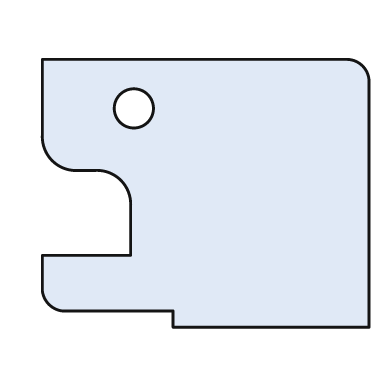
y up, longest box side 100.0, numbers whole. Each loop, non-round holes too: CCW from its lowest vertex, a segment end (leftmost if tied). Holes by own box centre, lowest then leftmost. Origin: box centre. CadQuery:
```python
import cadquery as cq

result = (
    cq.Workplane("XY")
    .moveTo(-10.0, -41.0)
    .lineTo(50.0, -41.0)
    .lineTo(50.0, 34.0)
    .threePointArc((48.0, 39.0), (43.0, 41.0))
    .lineTo(-50.0, 41.0)
    .lineTo(-50.0, 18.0)
    .threePointArc((-47.0, 10.0), (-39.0, 7.0))
    .lineTo(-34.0, 7.0)
    .threePointArc((-26.0, 4.0), (-23.0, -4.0))
    .lineTo(-23.0, -19.0)
    .lineTo(-50.0, -19.0)
    .lineTo(-50.0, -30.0)
    .threePointArc((-48.0, -34.0), (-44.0, -36.0))
    .lineTo(-10.0, -36.0)
    .close()
    .moveTo(-22.0, 26.0)
    .circle(6.0)
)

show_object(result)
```